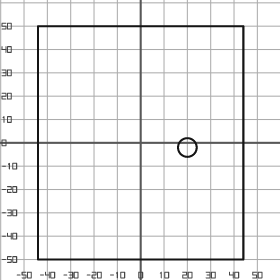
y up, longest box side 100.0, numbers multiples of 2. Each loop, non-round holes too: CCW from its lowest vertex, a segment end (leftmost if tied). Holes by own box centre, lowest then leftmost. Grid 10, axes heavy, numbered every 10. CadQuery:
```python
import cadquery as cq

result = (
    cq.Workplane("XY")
    .moveTo(-44.0, -50.0)
    .lineTo(44.0, -50.0)
    .lineTo(44.0, 50.0)
    .lineTo(-44.0, 50.0)
    .close()
    .moveTo(20.0, -2.0)
    .circle(4.0)
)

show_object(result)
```